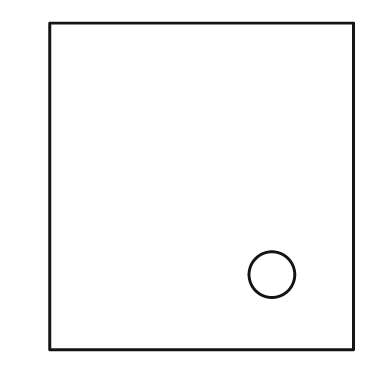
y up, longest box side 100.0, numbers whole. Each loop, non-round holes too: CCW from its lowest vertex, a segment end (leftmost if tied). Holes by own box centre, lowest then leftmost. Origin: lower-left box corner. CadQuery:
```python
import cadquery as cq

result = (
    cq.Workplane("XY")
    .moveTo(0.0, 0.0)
    .lineTo(93.0, 0.0)
    .lineTo(93.0, 100.0)
    .lineTo(0.0, 100.0)
    .close()
    .moveTo(68.0, 23.0)
    .circle(7.0)
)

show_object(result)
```